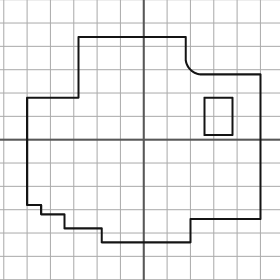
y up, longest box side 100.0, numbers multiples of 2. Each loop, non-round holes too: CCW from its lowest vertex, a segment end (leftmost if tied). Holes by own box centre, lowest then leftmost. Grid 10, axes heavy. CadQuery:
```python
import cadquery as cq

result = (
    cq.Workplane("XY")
    .moveTo(-18.0, -44.0)
    .lineTo(20.0, -44.0)
    .lineTo(20.0, -34.0)
    .lineTo(50.0, -34.0)
    .lineTo(50.0, 28.0)
    .lineTo(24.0, 28.0)
    .threePointArc((20.0, 30.0), (18.0, 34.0))
    .lineTo(18.0, 44.0)
    .lineTo(-28.0, 44.0)
    .lineTo(-28.0, 18.0)
    .lineTo(-50.0, 18.0)
    .lineTo(-50.0, -28.0)
    .lineTo(-44.0, -28.0)
    .lineTo(-44.0, -32.0)
    .lineTo(-34.0, -32.0)
    .lineTo(-34.0, -38.0)
    .lineTo(-18.0, -38.0)
    .close()
    .moveTo(26.0, 2.0)
    .lineTo(38.0, 2.0)
    .lineTo(38.0, 18.0)
    .lineTo(26.0, 18.0)
    .close()
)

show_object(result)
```